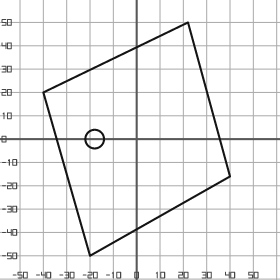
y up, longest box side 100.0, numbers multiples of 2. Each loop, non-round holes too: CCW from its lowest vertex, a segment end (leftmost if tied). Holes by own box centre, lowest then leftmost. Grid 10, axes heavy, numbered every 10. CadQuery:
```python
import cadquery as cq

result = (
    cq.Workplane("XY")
    .moveTo(-20.0, -50.0)
    .lineTo(40.0, -16.0)
    .lineTo(22.0, 50.0)
    .lineTo(-40.0, 20.0)
    .close()
    .moveTo(-18.0, 0.0)
    .circle(4.0)
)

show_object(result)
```